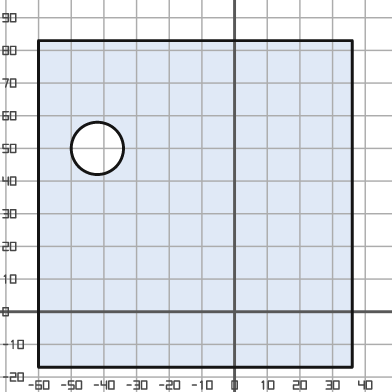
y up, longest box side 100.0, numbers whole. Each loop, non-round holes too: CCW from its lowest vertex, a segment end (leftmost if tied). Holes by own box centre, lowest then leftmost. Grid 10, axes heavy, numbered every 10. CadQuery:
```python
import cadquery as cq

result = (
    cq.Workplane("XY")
    .moveTo(-60.0, -17.0)
    .lineTo(36.0, -17.0)
    .lineTo(36.0, 83.0)
    .lineTo(-60.0, 83.0)
    .close()
    .moveTo(-42.0, 50.0)
    .circle(8.0)
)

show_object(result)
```